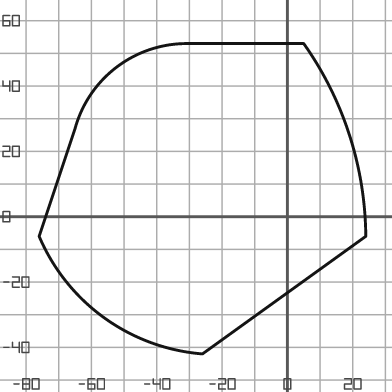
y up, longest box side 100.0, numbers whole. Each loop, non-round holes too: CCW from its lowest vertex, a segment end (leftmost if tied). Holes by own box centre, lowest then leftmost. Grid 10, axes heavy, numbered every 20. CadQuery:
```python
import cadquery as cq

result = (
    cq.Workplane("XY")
    .moveTo(-26.0, -42.0)
    .lineTo(24.0, -6.0)
    .threePointArc((19.0, 25.0), (5.0, 53.0))
    .lineTo(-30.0, 53.0)
    .threePointArc((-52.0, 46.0), (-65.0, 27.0))
    .lineTo(-76.0, -6.0)
    .threePointArc((-56.0, -31.0), (-26.0, -42.0))
    .close()
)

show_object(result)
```